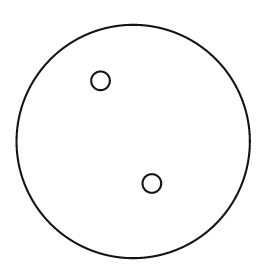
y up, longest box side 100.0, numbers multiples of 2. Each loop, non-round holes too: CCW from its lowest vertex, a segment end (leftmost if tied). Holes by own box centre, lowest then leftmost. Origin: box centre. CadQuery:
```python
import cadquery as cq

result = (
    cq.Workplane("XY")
    .moveTo(0.0, 0.0)
    .circle(50.0)
    .moveTo(8.0, -18.0)
    .circle(4.0)
    .moveTo(-14.0, 26.0)
    .circle(4.0)
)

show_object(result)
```